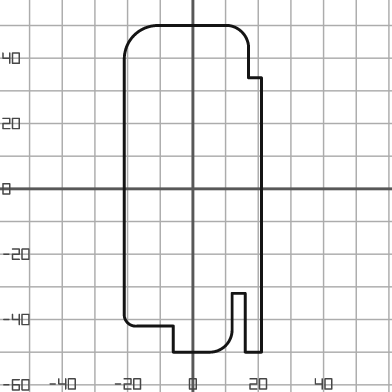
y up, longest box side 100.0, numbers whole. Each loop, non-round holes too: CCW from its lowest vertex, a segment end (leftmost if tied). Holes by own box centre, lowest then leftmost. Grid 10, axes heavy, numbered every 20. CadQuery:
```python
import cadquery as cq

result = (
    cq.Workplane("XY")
    .moveTo(-6.0, -50.0)
    .lineTo(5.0, -50.0)
    .threePointArc((10.0, -48.0), (12.0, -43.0))
    .lineTo(12.0, -32.0)
    .lineTo(16.0, -32.0)
    .lineTo(16.0, -50.0)
    .lineTo(21.0, -50.0)
    .lineTo(21.0, 34.0)
    .lineTo(17.0, 34.0)
    .lineTo(17.0, 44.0)
    .threePointArc((15.0, 48.0), (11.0, 50.0))
    .lineTo(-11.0, 50.0)
    .threePointArc((-18.0, 47.0), (-21.0, 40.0))
    .lineTo(-21.0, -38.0)
    .threePointArc((-20.0, -41.0), (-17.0, -42.0))
    .lineTo(-6.0, -42.0)
    .close()
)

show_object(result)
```